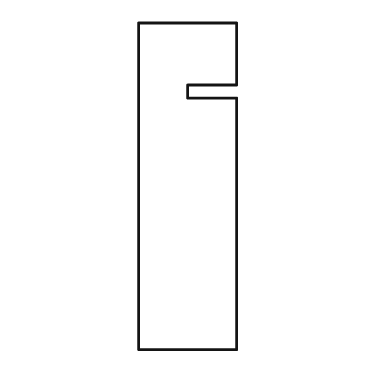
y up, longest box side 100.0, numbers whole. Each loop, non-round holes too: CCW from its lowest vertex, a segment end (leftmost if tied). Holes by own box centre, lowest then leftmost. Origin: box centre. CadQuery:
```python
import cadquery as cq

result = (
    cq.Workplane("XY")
    .moveTo(-15.0, -50.0)
    .lineTo(15.0, -50.0)
    .lineTo(15.0, 27.0)
    .lineTo(0.0, 27.0)
    .lineTo(0.0, 31.0)
    .lineTo(15.0, 31.0)
    .lineTo(15.0, 50.0)
    .lineTo(-15.0, 50.0)
    .close()
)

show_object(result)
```